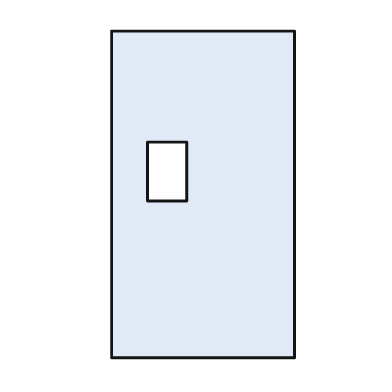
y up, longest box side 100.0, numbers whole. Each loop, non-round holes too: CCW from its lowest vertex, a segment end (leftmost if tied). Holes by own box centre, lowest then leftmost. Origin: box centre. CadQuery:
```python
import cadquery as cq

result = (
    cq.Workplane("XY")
    .moveTo(-28.0, -50.0)
    .lineTo(28.0, -50.0)
    .lineTo(28.0, 50.0)
    .lineTo(-28.0, 50.0)
    .close()
    .moveTo(-17.0, -2.0)
    .lineTo(-5.0, -2.0)
    .lineTo(-5.0, 16.0)
    .lineTo(-17.0, 16.0)
    .close()
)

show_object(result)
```